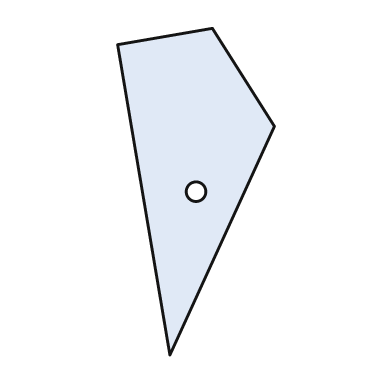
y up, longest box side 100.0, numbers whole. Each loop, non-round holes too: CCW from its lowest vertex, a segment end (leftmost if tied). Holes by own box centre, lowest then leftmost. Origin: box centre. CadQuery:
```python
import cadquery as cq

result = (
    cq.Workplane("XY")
    .moveTo(-8.0, -50.0)
    .lineTo(24.0, 20.0)
    .lineTo(5.0, 50.0)
    .lineTo(-24.0, 45.0)
    .close()
    .moveTo(0.0, 0.0)
    .circle(3.0)
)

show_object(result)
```